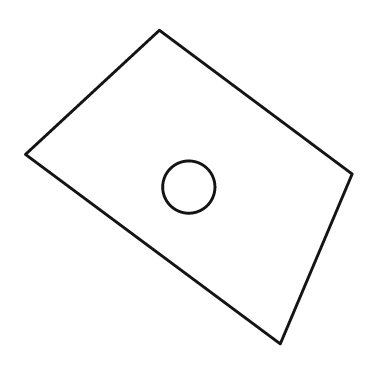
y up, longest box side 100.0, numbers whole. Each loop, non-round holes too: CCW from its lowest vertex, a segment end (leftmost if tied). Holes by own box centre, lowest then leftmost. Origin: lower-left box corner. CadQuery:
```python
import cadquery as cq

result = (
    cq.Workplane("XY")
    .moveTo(78.0, 0.0)
    .lineTo(100.0, 52.0)
    .lineTo(41.0, 96.0)
    .lineTo(0.0, 58.0)
    .close()
    .moveTo(50.0, 48.0)
    .circle(8.0)
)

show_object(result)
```